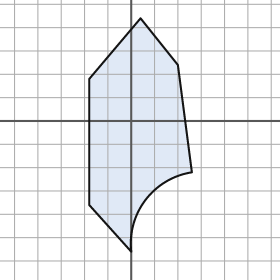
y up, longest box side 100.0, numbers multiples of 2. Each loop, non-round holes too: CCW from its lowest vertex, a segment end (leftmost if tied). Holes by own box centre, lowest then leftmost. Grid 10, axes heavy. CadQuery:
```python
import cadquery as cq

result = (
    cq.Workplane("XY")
    .moveTo(0.0, -56.0)
    .threePointArc((6.0, -34.0), (26.0, -22.0))
    .lineTo(20.0, 24.0)
    .lineTo(4.0, 44.0)
    .lineTo(-18.0, 18.0)
    .lineTo(-18.0, -36.0)
    .close()
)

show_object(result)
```